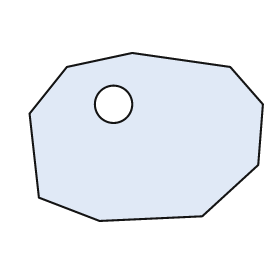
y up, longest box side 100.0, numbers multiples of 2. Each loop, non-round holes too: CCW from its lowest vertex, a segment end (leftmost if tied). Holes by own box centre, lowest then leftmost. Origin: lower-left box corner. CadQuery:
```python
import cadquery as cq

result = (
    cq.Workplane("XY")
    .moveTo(30.0, 0.0)
    .lineTo(74.0, 2.0)
    .lineTo(98.0, 24.0)
    .lineTo(100.0, 50.0)
    .lineTo(86.0, 66.0)
    .lineTo(44.0, 72.0)
    .lineTo(16.0, 66.0)
    .lineTo(0.0, 46.0)
    .lineTo(4.0, 10.0)
    .close()
    .moveTo(36.0, 50.0)
    .circle(8.0)
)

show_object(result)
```